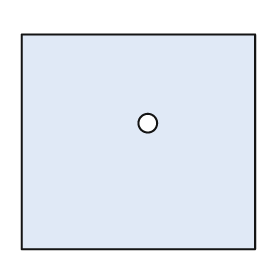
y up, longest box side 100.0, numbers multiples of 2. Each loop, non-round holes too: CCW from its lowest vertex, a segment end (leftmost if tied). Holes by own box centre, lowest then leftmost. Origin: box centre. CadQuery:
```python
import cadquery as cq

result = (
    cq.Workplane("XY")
    .moveTo(-50.0, -46.0)
    .lineTo(50.0, -46.0)
    .lineTo(50.0, 46.0)
    .lineTo(-50.0, 46.0)
    .close()
    .moveTo(4.0, 8.0)
    .circle(4.0)
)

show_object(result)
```